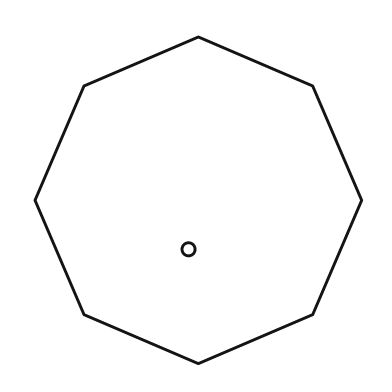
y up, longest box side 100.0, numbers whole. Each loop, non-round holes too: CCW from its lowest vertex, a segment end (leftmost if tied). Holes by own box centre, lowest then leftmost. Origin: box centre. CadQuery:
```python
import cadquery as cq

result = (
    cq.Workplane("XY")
    .moveTo(0.0, -50.0)
    .lineTo(35.0, -35.0)
    .lineTo(50.0, 0.0)
    .lineTo(35.0, 35.0)
    .lineTo(0.0, 50.0)
    .lineTo(-35.0, 35.0)
    .lineTo(-50.0, 0.0)
    .lineTo(-35.0, -35.0)
    .close()
    .moveTo(-3.0, -15.0)
    .circle(2.0)
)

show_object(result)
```